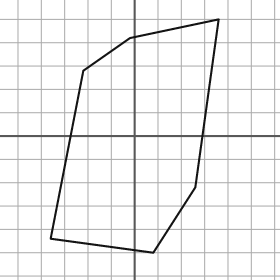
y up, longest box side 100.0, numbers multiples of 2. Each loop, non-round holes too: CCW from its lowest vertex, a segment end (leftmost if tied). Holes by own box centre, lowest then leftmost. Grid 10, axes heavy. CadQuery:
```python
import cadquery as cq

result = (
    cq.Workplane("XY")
    .moveTo(8.0, -50.0)
    .lineTo(26.0, -22.0)
    .lineTo(36.0, 50.0)
    .lineTo(-2.0, 42.0)
    .lineTo(-22.0, 28.0)
    .lineTo(-36.0, -44.0)
    .close()
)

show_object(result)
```